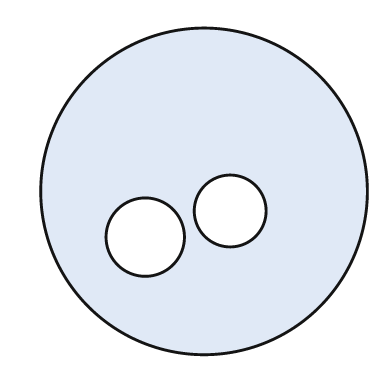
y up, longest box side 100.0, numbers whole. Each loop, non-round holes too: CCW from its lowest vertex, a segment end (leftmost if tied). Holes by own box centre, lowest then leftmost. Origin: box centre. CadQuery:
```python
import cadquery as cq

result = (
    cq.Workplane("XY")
    .moveTo(0.0, 0.0)
    .circle(50.0)
    .moveTo(-18.0, -14.0)
    .circle(12.0)
    .moveTo(8.0, -6.0)
    .circle(11.0)
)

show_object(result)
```